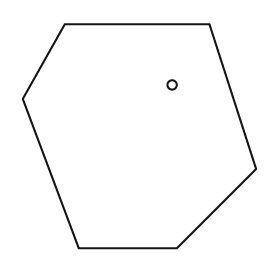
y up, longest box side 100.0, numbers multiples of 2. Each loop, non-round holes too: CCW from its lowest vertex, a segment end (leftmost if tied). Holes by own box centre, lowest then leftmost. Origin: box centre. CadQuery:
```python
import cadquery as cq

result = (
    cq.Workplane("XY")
    .moveTo(-26.0, -48.0)
    .lineTo(16.0, -48.0)
    .lineTo(50.0, -14.0)
    .lineTo(30.0, 48.0)
    .lineTo(-32.0, 48.0)
    .lineTo(-50.0, 16.0)
    .close()
    .moveTo(14.0, 22.0)
    .circle(2.0)
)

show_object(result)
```